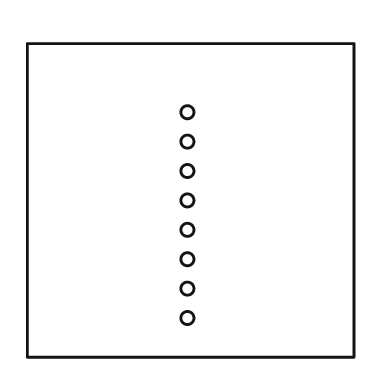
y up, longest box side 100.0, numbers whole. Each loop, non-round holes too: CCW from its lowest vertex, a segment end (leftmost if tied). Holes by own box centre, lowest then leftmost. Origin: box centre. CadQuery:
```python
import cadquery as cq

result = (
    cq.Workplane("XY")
    .moveTo(-50.0, -48.0)
    .lineTo(50.0, -48.0)
    .lineTo(50.0, 48.0)
    .lineTo(-50.0, 48.0)
    .close()
    .moveTo(-1.0, -36.0)
    .circle(2.0)
    .moveTo(-1.0, -27.0)
    .circle(2.0)
    .moveTo(-1.0, -18.0)
    .circle(2.0)
    .moveTo(-1.0, -9.0)
    .circle(2.0)
    .moveTo(-1.0, 0.0)
    .circle(2.0)
    .moveTo(-1.0, 9.0)
    .circle(2.0)
    .moveTo(-1.0, 18.0)
    .circle(2.0)
    .moveTo(-1.0, 27.0)
    .circle(2.0)
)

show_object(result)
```